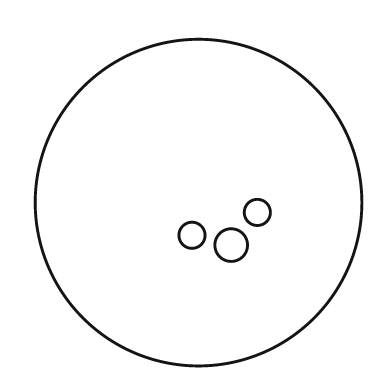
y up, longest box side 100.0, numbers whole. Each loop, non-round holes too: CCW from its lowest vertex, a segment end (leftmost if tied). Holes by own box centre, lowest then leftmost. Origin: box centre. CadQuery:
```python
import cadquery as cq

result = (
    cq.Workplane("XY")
    .moveTo(0.0, 0.0)
    .circle(50.0)
    .moveTo(10.0, -13.0)
    .circle(5.0)
    .moveTo(-2.0, -10.0)
    .circle(4.0)
    .moveTo(18.0, -3.0)
    .circle(4.0)
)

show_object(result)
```